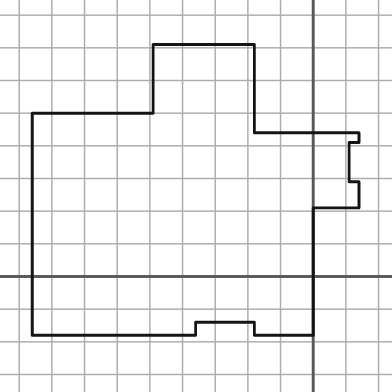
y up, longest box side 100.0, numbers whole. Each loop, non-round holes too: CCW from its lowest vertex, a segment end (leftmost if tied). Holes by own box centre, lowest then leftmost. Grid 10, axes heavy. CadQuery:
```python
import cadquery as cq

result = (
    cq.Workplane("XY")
    .moveTo(-86.0, -18.0)
    .lineTo(-36.0, -18.0)
    .lineTo(-36.0, -14.0)
    .lineTo(-18.0, -14.0)
    .lineTo(-18.0, -18.0)
    .lineTo(0.0, -18.0)
    .lineTo(0.0, 21.0)
    .lineTo(14.0, 21.0)
    .lineTo(14.0, 29.0)
    .lineTo(11.0, 29.0)
    .lineTo(11.0, 41.0)
    .lineTo(14.0, 41.0)
    .lineTo(14.0, 44.0)
    .lineTo(-18.0, 44.0)
    .lineTo(-18.0, 71.0)
    .lineTo(-49.0, 71.0)
    .lineTo(-49.0, 50.0)
    .lineTo(-86.0, 50.0)
    .close()
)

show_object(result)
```